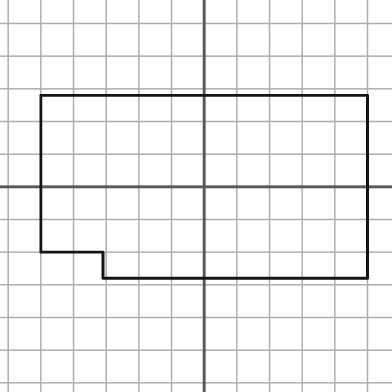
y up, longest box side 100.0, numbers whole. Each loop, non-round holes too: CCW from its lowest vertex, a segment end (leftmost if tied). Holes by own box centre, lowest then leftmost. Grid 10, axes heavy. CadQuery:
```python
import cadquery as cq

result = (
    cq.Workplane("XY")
    .moveTo(-31.0, -28.0)
    .lineTo(50.0, -28.0)
    .lineTo(50.0, 28.0)
    .lineTo(-50.0, 28.0)
    .lineTo(-50.0, -20.0)
    .lineTo(-31.0, -20.0)
    .close()
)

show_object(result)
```